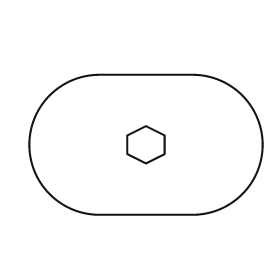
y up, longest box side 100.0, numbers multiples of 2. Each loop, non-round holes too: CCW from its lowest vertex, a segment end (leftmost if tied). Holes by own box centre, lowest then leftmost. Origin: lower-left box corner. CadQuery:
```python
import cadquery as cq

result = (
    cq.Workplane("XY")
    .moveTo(30.0, 0.0)
    .lineTo(70.0, 0.0)
    .threePointArc((100.0, 30.0), (70.0, 60.0))
    .lineTo(30.0, 60.0)
    .threePointArc((0.0, 30.0), (30.0, 0.0))
    .close()
    .moveTo(50.0, 22.0)
    .lineTo(58.0, 26.0)
    .lineTo(58.0, 34.0)
    .lineTo(50.0, 38.0)
    .lineTo(42.0, 34.0)
    .lineTo(42.0, 26.0)
    .close()
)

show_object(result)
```